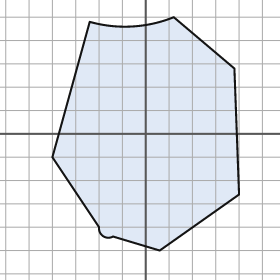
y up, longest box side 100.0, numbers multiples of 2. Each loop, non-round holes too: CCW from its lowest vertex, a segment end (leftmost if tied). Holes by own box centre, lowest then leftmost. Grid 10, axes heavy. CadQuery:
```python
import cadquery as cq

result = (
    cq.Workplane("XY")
    .moveTo(6.0, -50.0)
    .lineTo(40.0, -26.0)
    .lineTo(38.0, 28.0)
    .lineTo(12.0, 50.0)
    .threePointArc((-6.0, 46.0), (-24.0, 48.0))
    .lineTo(-40.0, -10.0)
    .lineTo(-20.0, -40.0)
    .threePointArc((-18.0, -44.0), (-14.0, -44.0))
    .close()
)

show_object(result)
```